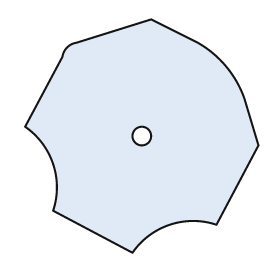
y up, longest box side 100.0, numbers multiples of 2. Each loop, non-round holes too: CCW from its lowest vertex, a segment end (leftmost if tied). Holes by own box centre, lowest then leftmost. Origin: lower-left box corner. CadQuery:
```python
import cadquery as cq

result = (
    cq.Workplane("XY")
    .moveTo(46.0, 0.0)
    .threePointArc((62.0, 12.0), (82.0, 12.0))
    .lineTo(100.0, 46.0)
    .lineTo(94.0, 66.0)
    .threePointArc((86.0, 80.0), (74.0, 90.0))
    .lineTo(54.0, 100.0)
    .lineTo(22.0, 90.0)
    .threePointArc((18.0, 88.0), (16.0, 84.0))
    .lineTo(0.0, 54.0)
    .threePointArc((12.0, 38.0), (12.0, 18.0))
    .close()
    .moveTo(50.0, 50.0)
    .circle(4.0)
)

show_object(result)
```